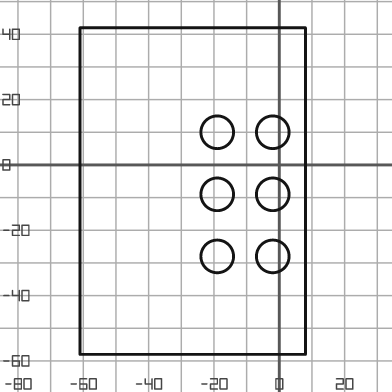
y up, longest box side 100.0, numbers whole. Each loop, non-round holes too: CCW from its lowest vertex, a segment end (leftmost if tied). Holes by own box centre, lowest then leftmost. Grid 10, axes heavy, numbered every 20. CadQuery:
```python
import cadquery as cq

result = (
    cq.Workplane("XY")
    .moveTo(-61.0, -58.0)
    .lineTo(8.0, -58.0)
    .lineTo(8.0, 42.0)
    .lineTo(-61.0, 42.0)
    .close()
    .moveTo(-19.0, -28.0)
    .circle(5.0)
    .moveTo(-2.0, -28.0)
    .circle(5.0)
    .moveTo(-19.0, -9.0)
    .circle(5.0)
    .moveTo(-2.0, -9.0)
    .circle(5.0)
    .moveTo(-19.0, 10.0)
    .circle(5.0)
    .moveTo(-2.0, 10.0)
    .circle(5.0)
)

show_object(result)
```